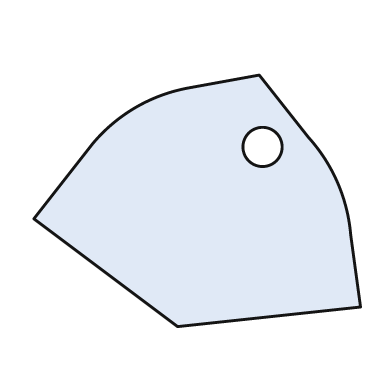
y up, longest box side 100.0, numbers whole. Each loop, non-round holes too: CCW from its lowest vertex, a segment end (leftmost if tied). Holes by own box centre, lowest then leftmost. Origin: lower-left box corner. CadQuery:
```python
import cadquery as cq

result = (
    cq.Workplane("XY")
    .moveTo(44.0, 0.0)
    .lineTo(100.0, 6.0)
    .lineTo(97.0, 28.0)
    .threePointArc((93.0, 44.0), (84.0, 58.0))
    .lineTo(69.0, 77.0)
    .lineTo(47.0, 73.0)
    .threePointArc((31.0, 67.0), (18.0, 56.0))
    .lineTo(0.0, 33.0)
    .close()
    .moveTo(70.0, 55.0)
    .circle(6.0)
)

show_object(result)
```